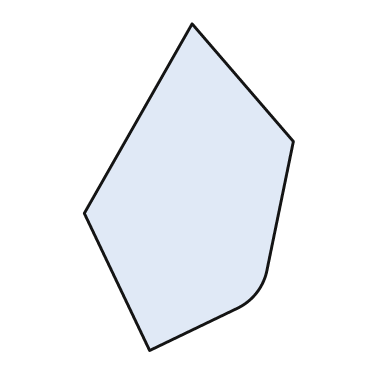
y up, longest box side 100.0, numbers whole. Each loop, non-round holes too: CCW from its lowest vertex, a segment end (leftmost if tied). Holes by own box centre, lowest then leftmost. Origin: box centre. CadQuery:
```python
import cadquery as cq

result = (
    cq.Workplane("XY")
    .moveTo(-12.0, -50.0)
    .lineTo(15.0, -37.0)
    .threePointArc((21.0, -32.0), (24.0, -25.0))
    .lineTo(32.0, 14.0)
    .lineTo(1.0, 50.0)
    .lineTo(-32.0, -8.0)
    .close()
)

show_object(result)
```